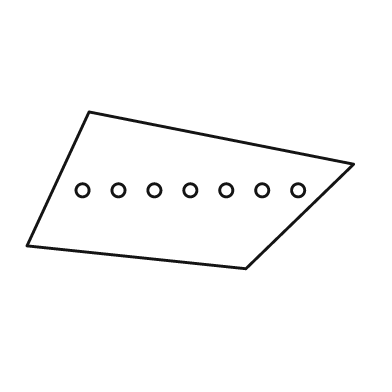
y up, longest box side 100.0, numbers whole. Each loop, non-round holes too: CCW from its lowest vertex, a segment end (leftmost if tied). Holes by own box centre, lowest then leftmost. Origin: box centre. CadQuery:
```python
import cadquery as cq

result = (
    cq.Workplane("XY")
    .moveTo(17.0, -24.0)
    .lineTo(50.0, 8.0)
    .lineTo(-31.0, 24.0)
    .lineTo(-50.0, -17.0)
    .close()
    .moveTo(-33.0, 0.0)
    .circle(2.0)
    .moveTo(-22.0, 0.0)
    .circle(2.0)
    .moveTo(-11.0, 0.0)
    .circle(2.0)
    .moveTo(0.0, 0.0)
    .circle(2.0)
    .moveTo(11.0, 0.0)
    .circle(2.0)
    .moveTo(22.0, 0.0)
    .circle(2.0)
    .moveTo(33.0, 0.0)
    .circle(2.0)
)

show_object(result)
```